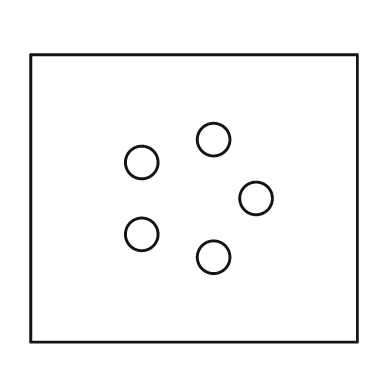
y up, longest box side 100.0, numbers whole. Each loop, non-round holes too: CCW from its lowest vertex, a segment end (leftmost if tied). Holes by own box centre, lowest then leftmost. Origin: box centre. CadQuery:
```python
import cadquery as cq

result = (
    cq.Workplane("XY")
    .moveTo(-50.0, -44.0)
    .lineTo(50.0, -44.0)
    .lineTo(50.0, 44.0)
    .lineTo(-50.0, 44.0)
    .close()
    .moveTo(6.0, -18.0)
    .circle(5.0)
    .moveTo(-16.0, -11.0)
    .circle(5.0)
    .moveTo(19.0, 0.0)
    .circle(5.0)
    .moveTo(-16.0, 11.0)
    .circle(5.0)
    .moveTo(6.0, 18.0)
    .circle(5.0)
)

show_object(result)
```